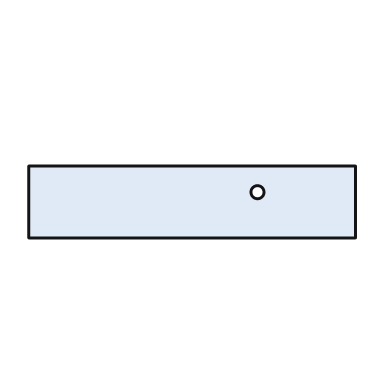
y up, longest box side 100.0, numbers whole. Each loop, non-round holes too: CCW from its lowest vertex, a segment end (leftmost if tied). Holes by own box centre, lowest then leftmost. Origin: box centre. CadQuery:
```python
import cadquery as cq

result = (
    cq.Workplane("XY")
    .moveTo(-50.0, -11.0)
    .lineTo(50.0, -11.0)
    .lineTo(50.0, 11.0)
    .lineTo(-50.0, 11.0)
    .close()
    .moveTo(20.0, 3.0)
    .circle(2.0)
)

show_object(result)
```